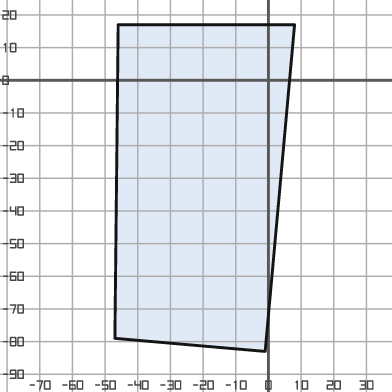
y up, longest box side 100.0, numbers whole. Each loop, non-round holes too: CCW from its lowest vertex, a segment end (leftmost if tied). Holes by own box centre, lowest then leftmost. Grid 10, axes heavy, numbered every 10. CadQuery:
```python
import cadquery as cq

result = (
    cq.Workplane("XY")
    .moveTo(-1.0, -83.0)
    .lineTo(8.0, 17.0)
    .lineTo(-46.0, 17.0)
    .lineTo(-47.0, -79.0)
    .close()
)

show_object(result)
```